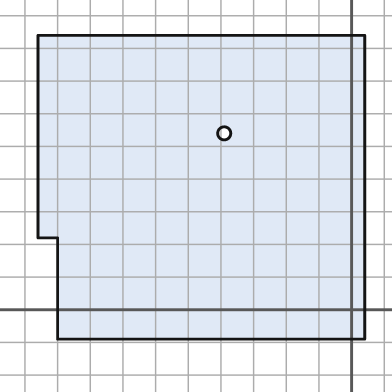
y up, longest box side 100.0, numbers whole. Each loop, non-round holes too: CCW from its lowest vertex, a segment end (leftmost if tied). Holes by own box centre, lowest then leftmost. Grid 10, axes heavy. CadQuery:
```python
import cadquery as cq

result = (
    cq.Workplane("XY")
    .moveTo(-90.0, -9.0)
    .lineTo(4.0, -9.0)
    .lineTo(4.0, 84.0)
    .lineTo(-96.0, 84.0)
    .lineTo(-96.0, 22.0)
    .lineTo(-90.0, 22.0)
    .close()
    .moveTo(-39.0, 54.0)
    .circle(2.0)
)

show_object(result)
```